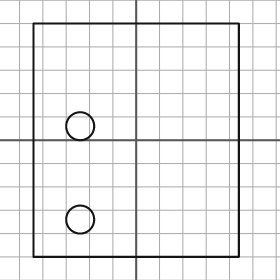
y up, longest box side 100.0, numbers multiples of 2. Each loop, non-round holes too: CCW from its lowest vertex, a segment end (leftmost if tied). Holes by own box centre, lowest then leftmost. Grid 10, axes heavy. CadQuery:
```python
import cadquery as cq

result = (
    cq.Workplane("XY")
    .moveTo(-44.0, -50.0)
    .lineTo(44.0, -50.0)
    .lineTo(44.0, 50.0)
    .lineTo(-44.0, 50.0)
    .close()
    .moveTo(-24.0, -34.0)
    .circle(6.0)
    .moveTo(-24.0, 6.0)
    .circle(6.0)
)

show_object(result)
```